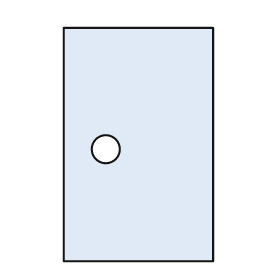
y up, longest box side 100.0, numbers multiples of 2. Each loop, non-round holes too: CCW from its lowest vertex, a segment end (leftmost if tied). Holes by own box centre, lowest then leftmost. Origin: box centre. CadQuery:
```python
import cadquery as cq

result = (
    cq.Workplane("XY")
    .moveTo(-32.0, -50.0)
    .lineTo(32.0, -50.0)
    .lineTo(32.0, 50.0)
    .lineTo(-32.0, 50.0)
    .close()
    .moveTo(-14.0, -2.0)
    .circle(6.0)
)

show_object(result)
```